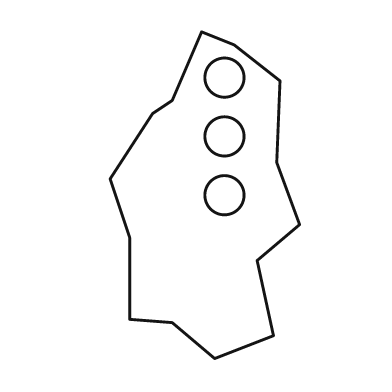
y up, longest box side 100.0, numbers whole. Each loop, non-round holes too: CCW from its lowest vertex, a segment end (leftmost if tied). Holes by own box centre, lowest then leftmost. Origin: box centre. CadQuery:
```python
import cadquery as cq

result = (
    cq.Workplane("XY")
    .moveTo(3.0, -50.0)
    .lineTo(21.0, -43.0)
    .lineTo(16.0, -20.0)
    .lineTo(29.0, -9.0)
    .lineTo(22.0, 10.0)
    .lineTo(23.0, 35.0)
    .lineTo(9.0, 46.0)
    .lineTo(-1.0, 50.0)
    .lineTo(-10.0, 29.0)
    .lineTo(-16.0, 25.0)
    .lineTo(-29.0, 5.0)
    .lineTo(-23.0, -13.0)
    .lineTo(-23.0, -38.0)
    .lineTo(-10.0, -39.0)
    .close()
    .moveTo(6.0, 0.0)
    .circle(6.0)
    .moveTo(6.0, 18.0)
    .circle(6.0)
    .moveTo(6.0, 36.0)
    .circle(6.0)
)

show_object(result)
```